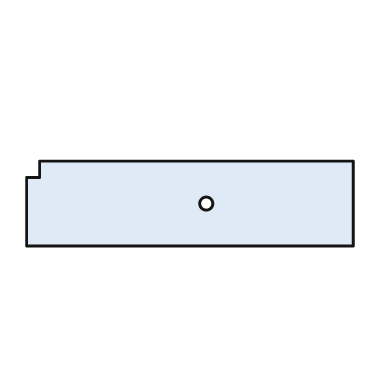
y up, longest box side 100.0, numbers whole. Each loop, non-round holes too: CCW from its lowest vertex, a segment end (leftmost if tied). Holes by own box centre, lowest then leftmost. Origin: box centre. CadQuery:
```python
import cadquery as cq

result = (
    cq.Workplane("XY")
    .moveTo(-50.0, -13.0)
    .lineTo(50.0, -13.0)
    .lineTo(50.0, 13.0)
    .lineTo(-46.0, 13.0)
    .lineTo(-46.0, 8.0)
    .lineTo(-50.0, 8.0)
    .close()
    .moveTo(5.0, 0.0)
    .circle(2.0)
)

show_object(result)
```